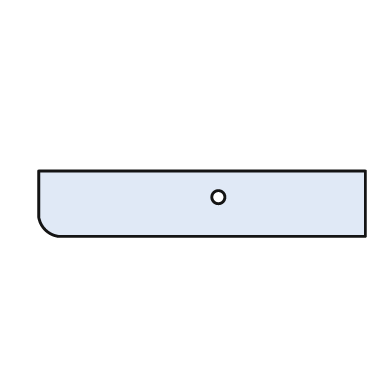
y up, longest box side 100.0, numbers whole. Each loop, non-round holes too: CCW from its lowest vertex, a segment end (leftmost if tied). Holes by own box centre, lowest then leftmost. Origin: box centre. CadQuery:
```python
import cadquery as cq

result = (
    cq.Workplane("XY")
    .moveTo(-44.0, -10.0)
    .lineTo(50.0, -10.0)
    .lineTo(50.0, 10.0)
    .lineTo(-50.0, 10.0)
    .lineTo(-50.0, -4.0)
    .threePointArc((-48.0, -8.0), (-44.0, -10.0))
    .close()
    .moveTo(5.0, 2.0)
    .circle(2.0)
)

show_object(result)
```